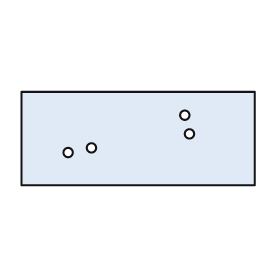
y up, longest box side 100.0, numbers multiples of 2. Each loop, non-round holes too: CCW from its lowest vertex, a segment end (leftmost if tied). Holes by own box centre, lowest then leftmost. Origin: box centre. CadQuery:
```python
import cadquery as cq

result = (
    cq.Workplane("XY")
    .moveTo(-50.0, -20.0)
    .lineTo(50.0, -20.0)
    .lineTo(50.0, 20.0)
    .lineTo(-50.0, 20.0)
    .close()
    .moveTo(-30.0, -6.0)
    .circle(2.0)
    .moveTo(-20.0, -4.0)
    .circle(2.0)
    .moveTo(22.0, 2.0)
    .circle(2.0)
    .moveTo(20.0, 10.0)
    .circle(2.0)
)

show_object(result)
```